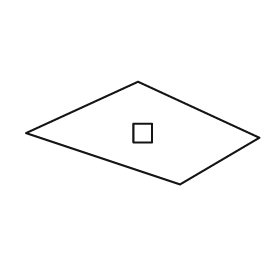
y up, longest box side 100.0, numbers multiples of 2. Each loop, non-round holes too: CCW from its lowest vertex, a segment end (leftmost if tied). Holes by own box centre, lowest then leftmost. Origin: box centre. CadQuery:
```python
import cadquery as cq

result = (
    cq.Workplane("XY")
    .moveTo(16.0, -22.0)
    .lineTo(50.0, -2.0)
    .lineTo(-2.0, 22.0)
    .lineTo(-50.0, 0.0)
    .close()
    .moveTo(-4.0, -4.0)
    .lineTo(4.0, -4.0)
    .lineTo(4.0, 4.0)
    .lineTo(-4.0, 4.0)
    .close()
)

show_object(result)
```